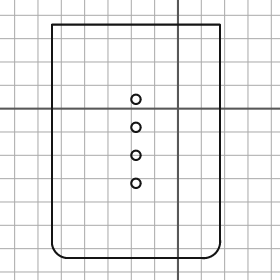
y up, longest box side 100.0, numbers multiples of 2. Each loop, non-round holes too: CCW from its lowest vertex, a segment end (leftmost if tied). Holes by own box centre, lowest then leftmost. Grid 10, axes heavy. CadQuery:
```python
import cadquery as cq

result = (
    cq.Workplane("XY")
    .moveTo(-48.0, -64.0)
    .lineTo(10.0, -64.0)
    .threePointArc((16.0, -62.0), (18.0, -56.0))
    .lineTo(18.0, 36.0)
    .lineTo(-54.0, 36.0)
    .lineTo(-54.0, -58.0)
    .threePointArc((-52.0, -62.0), (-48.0, -64.0))
    .close()
    .moveTo(-18.0, -32.0)
    .circle(2.0)
    .moveTo(-18.0, -20.0)
    .circle(2.0)
    .moveTo(-18.0, -8.0)
    .circle(2.0)
    .moveTo(-18.0, 4.0)
    .circle(2.0)
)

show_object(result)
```